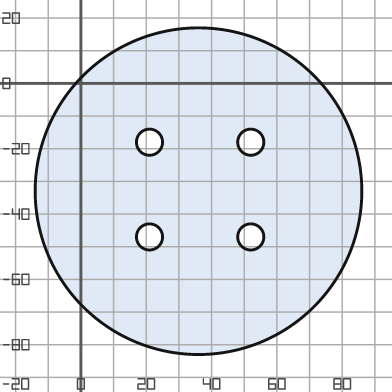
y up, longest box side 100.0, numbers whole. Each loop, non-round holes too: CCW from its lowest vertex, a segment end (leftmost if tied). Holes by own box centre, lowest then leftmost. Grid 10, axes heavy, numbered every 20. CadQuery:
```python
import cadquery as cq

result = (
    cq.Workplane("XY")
    .moveTo(36.0, -33.0)
    .circle(50.0)
    .moveTo(21.0, -47.0)
    .circle(4.0)
    .moveTo(52.0, -47.0)
    .circle(4.0)
    .moveTo(21.0, -18.0)
    .circle(4.0)
    .moveTo(52.0, -18.0)
    .circle(4.0)
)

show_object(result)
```